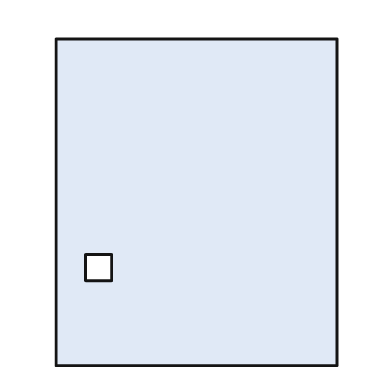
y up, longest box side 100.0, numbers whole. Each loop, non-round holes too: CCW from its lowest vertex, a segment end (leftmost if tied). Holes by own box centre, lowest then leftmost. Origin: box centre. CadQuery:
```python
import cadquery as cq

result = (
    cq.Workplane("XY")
    .moveTo(-43.0, -50.0)
    .lineTo(43.0, -50.0)
    .lineTo(43.0, 50.0)
    .lineTo(-43.0, 50.0)
    .close()
    .moveTo(-34.0, -24.0)
    .lineTo(-26.0, -24.0)
    .lineTo(-26.0, -16.0)
    .lineTo(-34.0, -16.0)
    .close()
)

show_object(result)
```